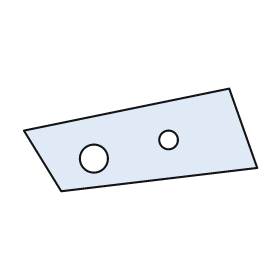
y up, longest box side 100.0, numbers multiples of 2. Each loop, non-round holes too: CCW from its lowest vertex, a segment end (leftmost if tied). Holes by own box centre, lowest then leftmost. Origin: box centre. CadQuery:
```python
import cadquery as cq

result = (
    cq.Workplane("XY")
    .moveTo(-34.0, -22.0)
    .lineTo(50.0, -12.0)
    .lineTo(38.0, 22.0)
    .lineTo(-50.0, 4.0)
    .close()
    .moveTo(-20.0, -8.0)
    .circle(6.0)
    .moveTo(12.0, 0.0)
    .circle(4.0)
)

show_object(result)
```